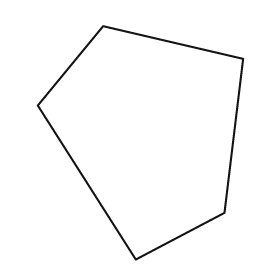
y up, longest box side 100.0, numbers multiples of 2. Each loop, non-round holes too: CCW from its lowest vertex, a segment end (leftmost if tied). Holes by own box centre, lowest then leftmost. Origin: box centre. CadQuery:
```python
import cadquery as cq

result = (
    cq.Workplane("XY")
    .moveTo(-2.0, -50.0)
    .lineTo(36.0, -30.0)
    .lineTo(44.0, 36.0)
    .lineTo(-16.0, 50.0)
    .lineTo(-44.0, 16.0)
    .close()
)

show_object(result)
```